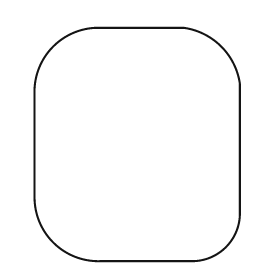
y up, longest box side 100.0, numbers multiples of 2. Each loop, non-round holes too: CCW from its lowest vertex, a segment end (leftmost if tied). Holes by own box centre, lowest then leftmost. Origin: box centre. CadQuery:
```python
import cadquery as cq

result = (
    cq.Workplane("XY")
    .moveTo(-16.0, -50.0)
    .lineTo(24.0, -50.0)
    .threePointArc((38.0, -44.0), (44.0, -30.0))
    .lineTo(44.0, 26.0)
    .threePointArc((36.0, 42.0), (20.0, 50.0))
    .lineTo(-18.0, 50.0)
    .threePointArc((-36.0, 42.0), (-44.0, 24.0))
    .lineTo(-44.0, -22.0)
    .threePointArc((-36.0, -42.0), (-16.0, -50.0))
    .close()
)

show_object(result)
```